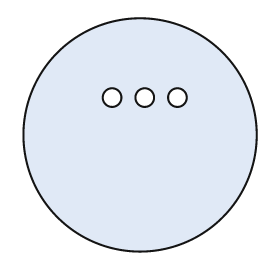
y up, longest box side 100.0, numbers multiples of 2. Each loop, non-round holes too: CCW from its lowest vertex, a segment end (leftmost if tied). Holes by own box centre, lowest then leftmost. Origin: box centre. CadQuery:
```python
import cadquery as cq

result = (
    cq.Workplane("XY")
    .moveTo(0.0, 0.0)
    .circle(50.0)
    .moveTo(-12.0, 16.0)
    .circle(4.0)
    .moveTo(2.0, 16.0)
    .circle(4.0)
    .moveTo(16.0, 16.0)
    .circle(4.0)
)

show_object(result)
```